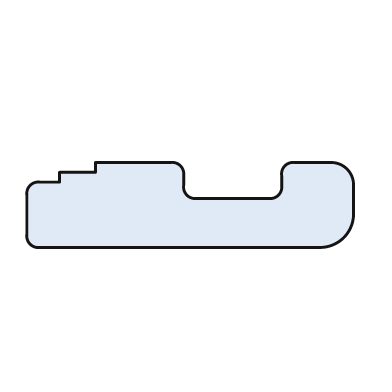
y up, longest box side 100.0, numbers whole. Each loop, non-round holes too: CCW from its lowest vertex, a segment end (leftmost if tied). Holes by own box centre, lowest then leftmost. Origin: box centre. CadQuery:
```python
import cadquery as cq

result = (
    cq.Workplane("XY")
    .moveTo(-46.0, -13.0)
    .lineTo(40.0, -13.0)
    .threePointArc((47.0, -10.0), (50.0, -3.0))
    .lineTo(50.0, 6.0)
    .threePointArc((48.0, 11.0), (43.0, 13.0))
    .lineTo(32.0, 13.0)
    .threePointArc((29.0, 12.0), (28.0, 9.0))
    .lineTo(28.0, 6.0)
    .threePointArc((27.0, 3.0), (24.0, 2.0))
    .lineTo(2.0, 2.0)
    .threePointArc((-1.0, 3.0), (-2.0, 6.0))
    .lineTo(-2.0, 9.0)
    .threePointArc((-3.0, 12.0), (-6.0, 13.0))
    .lineTo(-29.0, 13.0)
    .lineTo(-29.0, 10.0)
    .lineTo(-40.0, 10.0)
    .lineTo(-40.0, 7.0)
    .lineTo(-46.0, 7.0)
    .threePointArc((-49.0, 6.0), (-50.0, 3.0))
    .lineTo(-50.0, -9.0)
    .threePointArc((-49.0, -12.0), (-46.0, -13.0))
    .close()
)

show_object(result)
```